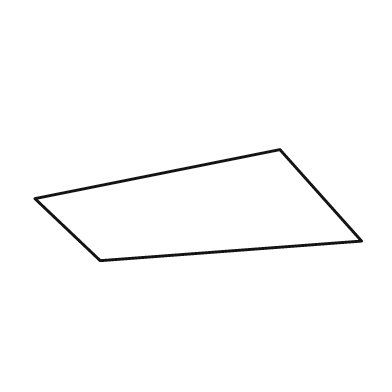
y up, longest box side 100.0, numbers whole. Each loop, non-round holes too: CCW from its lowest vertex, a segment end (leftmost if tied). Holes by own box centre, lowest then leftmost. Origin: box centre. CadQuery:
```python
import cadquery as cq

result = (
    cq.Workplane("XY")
    .moveTo(-30.0, -17.0)
    .lineTo(50.0, -11.0)
    .lineTo(25.0, 17.0)
    .lineTo(-50.0, 2.0)
    .close()
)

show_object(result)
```